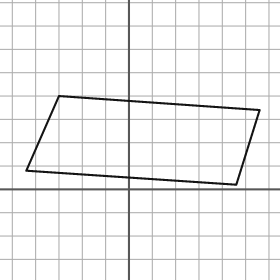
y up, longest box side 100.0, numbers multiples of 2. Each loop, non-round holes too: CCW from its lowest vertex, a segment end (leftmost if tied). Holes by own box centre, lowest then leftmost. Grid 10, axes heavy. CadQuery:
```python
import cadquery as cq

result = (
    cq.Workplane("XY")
    .moveTo(46.0, 2.0)
    .lineTo(56.0, 34.0)
    .lineTo(-30.0, 40.0)
    .lineTo(-44.0, 8.0)
    .close()
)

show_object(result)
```